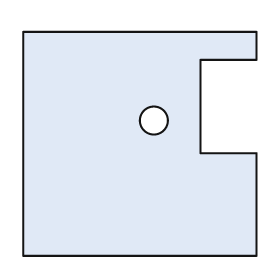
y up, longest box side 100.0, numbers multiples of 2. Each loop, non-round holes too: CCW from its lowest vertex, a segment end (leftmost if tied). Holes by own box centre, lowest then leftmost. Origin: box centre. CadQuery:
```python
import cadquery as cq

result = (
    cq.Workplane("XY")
    .moveTo(-50.0, -48.0)
    .lineTo(50.0, -48.0)
    .lineTo(50.0, -4.0)
    .lineTo(26.0, -4.0)
    .lineTo(26.0, 36.0)
    .lineTo(50.0, 36.0)
    .lineTo(50.0, 48.0)
    .lineTo(-50.0, 48.0)
    .close()
    .moveTo(6.0, 10.0)
    .circle(6.0)
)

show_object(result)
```